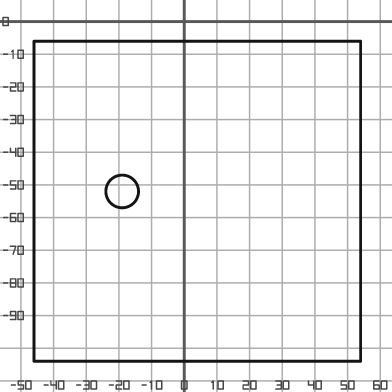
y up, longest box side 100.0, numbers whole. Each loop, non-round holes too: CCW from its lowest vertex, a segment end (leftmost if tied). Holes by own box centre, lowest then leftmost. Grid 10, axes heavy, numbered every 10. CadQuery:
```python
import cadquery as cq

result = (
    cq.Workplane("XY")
    .moveTo(-46.0, -104.0)
    .lineTo(54.0, -104.0)
    .lineTo(54.0, -6.0)
    .lineTo(-46.0, -6.0)
    .close()
    .moveTo(-19.0, -52.0)
    .circle(5.0)
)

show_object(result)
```